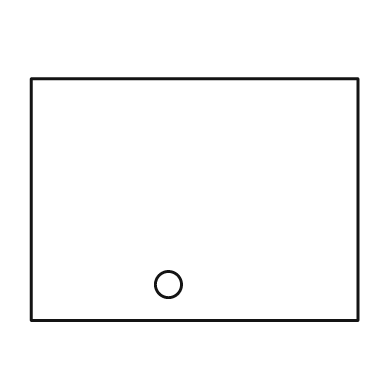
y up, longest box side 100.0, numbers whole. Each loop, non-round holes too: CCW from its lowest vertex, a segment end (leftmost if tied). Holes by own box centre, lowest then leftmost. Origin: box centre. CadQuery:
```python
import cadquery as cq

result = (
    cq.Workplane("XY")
    .moveTo(-50.0, -37.0)
    .lineTo(50.0, -37.0)
    .lineTo(50.0, 37.0)
    .lineTo(-50.0, 37.0)
    .close()
    .moveTo(-8.0, -26.0)
    .circle(4.0)
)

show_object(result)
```